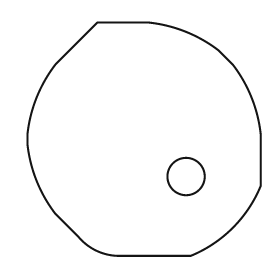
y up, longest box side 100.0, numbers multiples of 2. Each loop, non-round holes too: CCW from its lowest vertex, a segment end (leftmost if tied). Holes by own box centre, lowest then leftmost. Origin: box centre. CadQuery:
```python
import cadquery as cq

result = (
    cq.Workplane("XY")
    .moveTo(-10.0, -50.0)
    .lineTo(20.0, -50.0)
    .threePointArc((38.0, -38.0), (50.0, -20.0))
    .lineTo(50.0, 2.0)
    .threePointArc((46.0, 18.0), (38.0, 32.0))
    .lineTo(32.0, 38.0)
    .threePointArc((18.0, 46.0), (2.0, 50.0))
    .lineTo(-20.0, 50.0)
    .lineTo(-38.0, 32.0)
    .threePointArc((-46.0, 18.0), (-50.0, 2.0))
    .lineTo(-50.0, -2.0)
    .threePointArc((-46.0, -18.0), (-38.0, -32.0))
    .lineTo(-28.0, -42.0)
    .threePointArc((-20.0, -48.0), (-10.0, -50.0))
    .close()
    .moveTo(18.0, -16.0)
    .circle(8.0)
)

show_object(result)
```